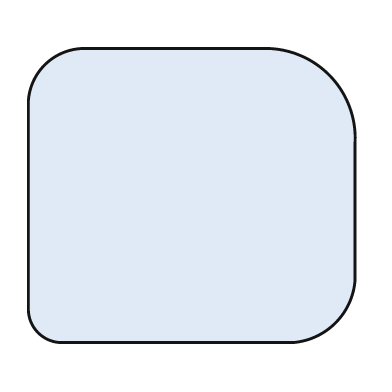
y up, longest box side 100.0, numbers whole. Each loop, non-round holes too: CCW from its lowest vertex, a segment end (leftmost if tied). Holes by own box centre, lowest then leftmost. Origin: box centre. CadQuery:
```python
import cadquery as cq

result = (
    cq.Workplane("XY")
    .moveTo(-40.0, -45.0)
    .lineTo(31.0, -45.0)
    .threePointArc((44.0, -39.0), (50.0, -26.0))
    .lineTo(50.0, 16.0)
    .threePointArc((42.0, 37.0), (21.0, 45.0))
    .lineTo(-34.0, 45.0)
    .threePointArc((-45.0, 40.0), (-50.0, 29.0))
    .lineTo(-50.0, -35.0)
    .threePointArc((-47.0, -42.0), (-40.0, -45.0))
    .close()
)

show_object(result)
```